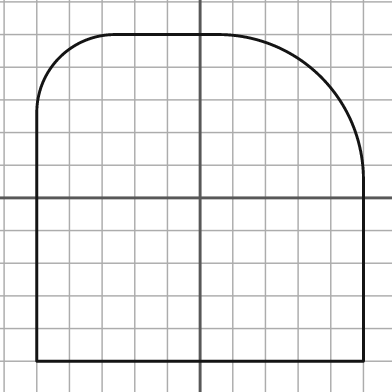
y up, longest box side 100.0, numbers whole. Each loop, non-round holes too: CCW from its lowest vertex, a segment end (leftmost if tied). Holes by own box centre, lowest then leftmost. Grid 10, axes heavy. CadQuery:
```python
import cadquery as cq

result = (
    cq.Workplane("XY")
    .moveTo(-50.0, -50.0)
    .lineTo(50.0, -50.0)
    .lineTo(50.0, 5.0)
    .threePointArc((37.0, 37.0), (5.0, 50.0))
    .lineTo(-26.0, 50.0)
    .threePointArc((-43.0, 43.0), (-50.0, 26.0))
    .close()
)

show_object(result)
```